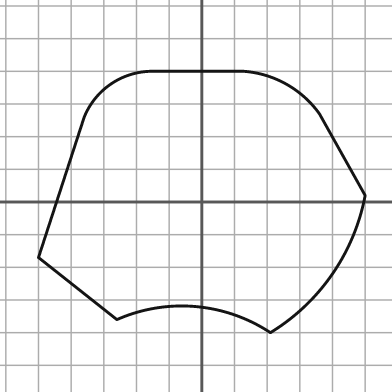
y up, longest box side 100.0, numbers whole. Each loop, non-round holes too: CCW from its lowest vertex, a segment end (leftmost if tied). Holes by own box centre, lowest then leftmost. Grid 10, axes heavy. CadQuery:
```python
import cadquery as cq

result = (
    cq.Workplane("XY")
    .moveTo(21.0, -40.0)
    .threePointArc((40.0, -22.0), (50.0, 2.0))
    .lineTo(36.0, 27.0)
    .threePointArc((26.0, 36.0), (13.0, 40.0))
    .lineTo(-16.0, 40.0)
    .threePointArc((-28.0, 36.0), (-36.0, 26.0))
    .lineTo(-50.0, -17.0)
    .lineTo(-26.0, -36.0)
    .threePointArc((-2.0, -32.0), (21.0, -40.0))
    .close()
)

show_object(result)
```